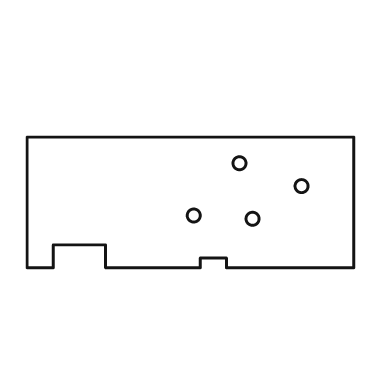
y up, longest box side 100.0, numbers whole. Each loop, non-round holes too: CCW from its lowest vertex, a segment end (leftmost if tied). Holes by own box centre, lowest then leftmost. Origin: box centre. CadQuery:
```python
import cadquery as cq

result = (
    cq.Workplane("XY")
    .moveTo(-50.0, -20.0)
    .lineTo(-42.0, -20.0)
    .lineTo(-42.0, -13.0)
    .lineTo(-26.0, -13.0)
    .lineTo(-26.0, -20.0)
    .lineTo(3.0, -20.0)
    .lineTo(3.0, -17.0)
    .lineTo(11.0, -17.0)
    .lineTo(11.0, -20.0)
    .lineTo(50.0, -20.0)
    .lineTo(50.0, 20.0)
    .lineTo(-50.0, 20.0)
    .close()
    .moveTo(19.0, -5.0)
    .circle(2.0)
    .moveTo(1.0, -4.0)
    .circle(2.0)
    .moveTo(34.0, 5.0)
    .circle(2.0)
    .moveTo(15.0, 12.0)
    .circle(2.0)
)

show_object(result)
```